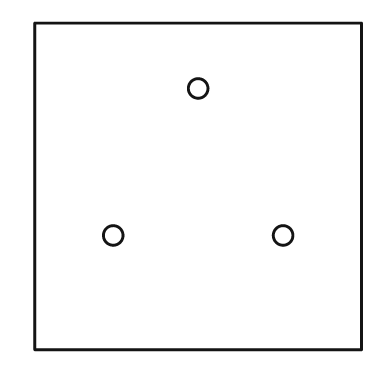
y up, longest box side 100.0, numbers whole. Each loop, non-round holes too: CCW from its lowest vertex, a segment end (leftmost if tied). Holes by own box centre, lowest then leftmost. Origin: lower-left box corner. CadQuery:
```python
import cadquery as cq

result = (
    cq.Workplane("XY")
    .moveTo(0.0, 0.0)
    .lineTo(100.0, 0.0)
    .lineTo(100.0, 100.0)
    .lineTo(0.0, 100.0)
    .close()
    .moveTo(24.0, 35.0)
    .circle(3.0)
    .moveTo(76.0, 35.0)
    .circle(3.0)
    .moveTo(50.0, 80.0)
    .circle(3.0)
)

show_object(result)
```